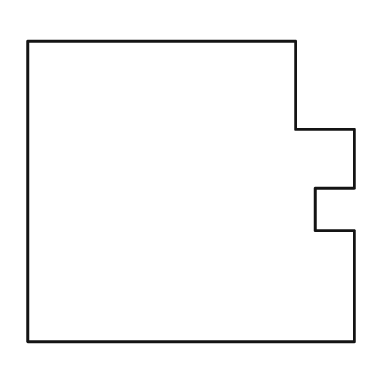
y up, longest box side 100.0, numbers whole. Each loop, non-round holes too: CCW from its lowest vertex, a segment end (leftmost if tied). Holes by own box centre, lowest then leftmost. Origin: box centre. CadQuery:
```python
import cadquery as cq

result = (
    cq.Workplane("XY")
    .moveTo(-50.0, -46.0)
    .lineTo(50.0, -46.0)
    .lineTo(50.0, -12.0)
    .lineTo(38.0, -12.0)
    .lineTo(38.0, 1.0)
    .lineTo(50.0, 1.0)
    .lineTo(50.0, 19.0)
    .lineTo(32.0, 19.0)
    .lineTo(32.0, 46.0)
    .lineTo(-50.0, 46.0)
    .close()
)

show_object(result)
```